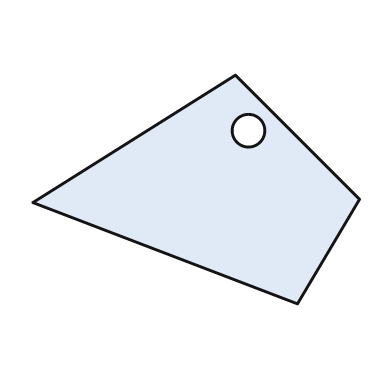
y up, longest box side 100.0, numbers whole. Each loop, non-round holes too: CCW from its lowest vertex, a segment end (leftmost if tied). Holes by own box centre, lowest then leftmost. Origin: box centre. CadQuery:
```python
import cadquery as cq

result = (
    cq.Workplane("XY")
    .moveTo(31.0, -35.0)
    .lineTo(50.0, -3.0)
    .lineTo(12.0, 35.0)
    .lineTo(-50.0, -4.0)
    .close()
    .moveTo(16.0, 18.0)
    .circle(5.0)
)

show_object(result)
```